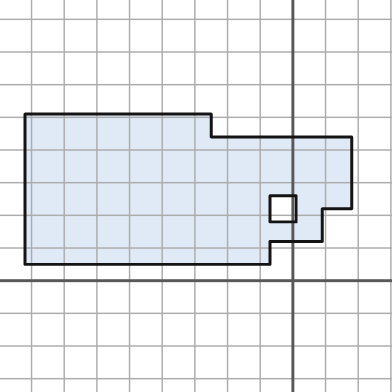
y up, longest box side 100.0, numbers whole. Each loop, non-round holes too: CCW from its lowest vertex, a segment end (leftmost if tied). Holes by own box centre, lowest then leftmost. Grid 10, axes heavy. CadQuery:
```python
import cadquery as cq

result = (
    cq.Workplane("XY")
    .moveTo(-82.0, 5.0)
    .lineTo(-7.0, 5.0)
    .lineTo(-7.0, 12.0)
    .lineTo(9.0, 12.0)
    .lineTo(9.0, 22.0)
    .lineTo(18.0, 22.0)
    .lineTo(18.0, 44.0)
    .lineTo(-25.0, 44.0)
    .lineTo(-25.0, 51.0)
    .lineTo(-82.0, 51.0)
    .close()
    .moveTo(-7.0, 18.0)
    .lineTo(1.0, 18.0)
    .lineTo(1.0, 26.0)
    .lineTo(-7.0, 26.0)
    .close()
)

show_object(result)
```